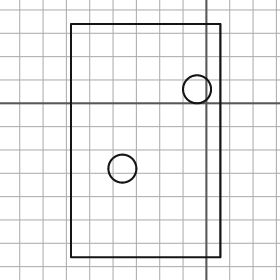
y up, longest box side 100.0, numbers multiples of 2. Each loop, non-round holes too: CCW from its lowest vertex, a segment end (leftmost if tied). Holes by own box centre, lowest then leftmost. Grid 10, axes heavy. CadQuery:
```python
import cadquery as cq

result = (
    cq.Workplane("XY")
    .moveTo(-58.0, -66.0)
    .lineTo(6.0, -66.0)
    .lineTo(6.0, 34.0)
    .lineTo(-58.0, 34.0)
    .close()
    .moveTo(-36.0, -28.0)
    .circle(6.0)
    .moveTo(-4.0, 6.0)
    .circle(6.0)
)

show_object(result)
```